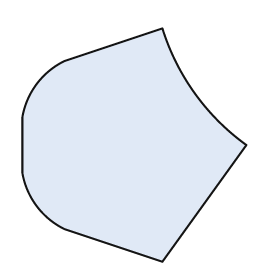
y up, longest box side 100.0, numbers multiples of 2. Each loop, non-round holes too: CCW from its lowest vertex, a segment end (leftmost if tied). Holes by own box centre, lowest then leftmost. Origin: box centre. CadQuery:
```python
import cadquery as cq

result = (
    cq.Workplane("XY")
    .moveTo(12.0, -50.0)
    .lineTo(48.0, 0.0)
    .threePointArc((26.0, 22.0), (12.0, 50.0))
    .lineTo(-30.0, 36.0)
    .threePointArc((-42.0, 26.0), (-48.0, 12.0))
    .lineTo(-48.0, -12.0)
    .threePointArc((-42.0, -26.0), (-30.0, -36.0))
    .close()
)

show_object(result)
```